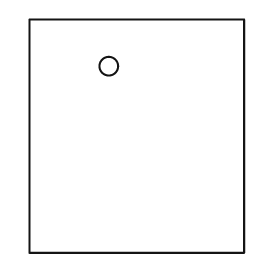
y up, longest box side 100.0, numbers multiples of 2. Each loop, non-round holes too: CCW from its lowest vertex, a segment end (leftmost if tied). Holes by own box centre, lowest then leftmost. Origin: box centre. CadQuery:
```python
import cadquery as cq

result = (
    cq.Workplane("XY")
    .moveTo(-46.0, -50.0)
    .lineTo(46.0, -50.0)
    .lineTo(46.0, 50.0)
    .lineTo(-46.0, 50.0)
    .close()
    .moveTo(-12.0, 30.0)
    .circle(4.0)
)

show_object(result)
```